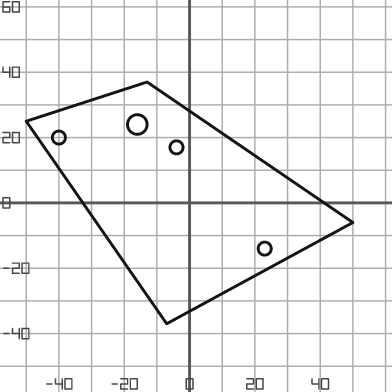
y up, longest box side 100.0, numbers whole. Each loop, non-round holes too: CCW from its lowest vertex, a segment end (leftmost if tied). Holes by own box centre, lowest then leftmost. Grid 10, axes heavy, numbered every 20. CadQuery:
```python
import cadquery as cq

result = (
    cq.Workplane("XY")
    .moveTo(-7.0, -37.0)
    .lineTo(50.0, -6.0)
    .lineTo(-13.0, 37.0)
    .lineTo(-50.0, 25.0)
    .close()
    .moveTo(23.0, -14.0)
    .circle(2.0)
    .moveTo(-4.0, 17.0)
    .circle(2.0)
    .moveTo(-40.0, 20.0)
    .circle(2.0)
    .moveTo(-16.0, 24.0)
    .circle(3.0)
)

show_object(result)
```